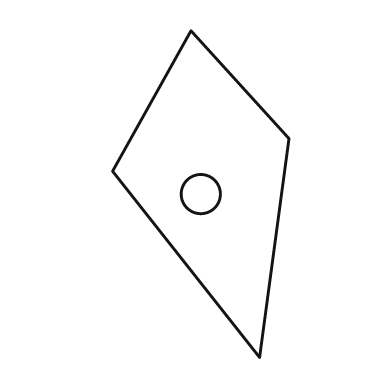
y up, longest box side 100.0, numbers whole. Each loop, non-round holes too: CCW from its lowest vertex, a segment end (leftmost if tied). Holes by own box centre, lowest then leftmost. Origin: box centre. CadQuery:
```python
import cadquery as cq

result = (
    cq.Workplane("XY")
    .moveTo(18.0, -50.0)
    .lineTo(27.0, 17.0)
    .lineTo(-3.0, 50.0)
    .lineTo(-27.0, 7.0)
    .close()
    .moveTo(0.0, 0.0)
    .circle(6.0)
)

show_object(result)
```